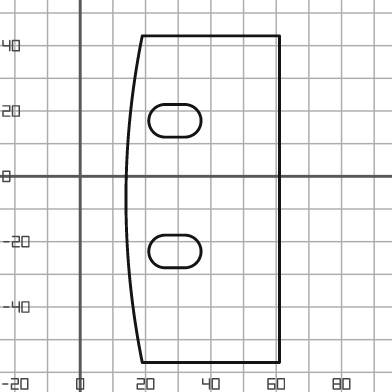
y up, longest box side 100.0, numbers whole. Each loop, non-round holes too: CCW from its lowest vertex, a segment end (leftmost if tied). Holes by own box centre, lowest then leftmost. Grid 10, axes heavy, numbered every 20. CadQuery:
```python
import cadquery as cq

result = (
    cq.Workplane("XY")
    .moveTo(19.0, -57.0)
    .lineTo(61.0, -57.0)
    .lineTo(61.0, 43.0)
    .lineTo(19.0, 43.0)
    .threePointArc((14.0, -7.0), (19.0, -57.0))
    .close()
    .moveTo(26.0, -28.0)
    .lineTo(32.0, -28.0)
    .threePointArc((37.0, -23.0), (32.0, -18.0))
    .lineTo(26.0, -18.0)
    .threePointArc((21.0, -23.0), (26.0, -28.0))
    .close()
    .moveTo(26.0, 12.0)
    .lineTo(32.0, 12.0)
    .threePointArc((37.0, 17.0), (32.0, 22.0))
    .lineTo(26.0, 22.0)
    .threePointArc((21.0, 17.0), (26.0, 12.0))
    .close()
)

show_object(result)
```